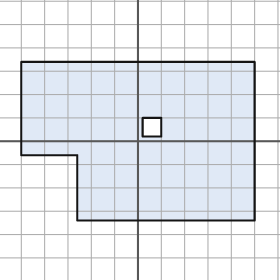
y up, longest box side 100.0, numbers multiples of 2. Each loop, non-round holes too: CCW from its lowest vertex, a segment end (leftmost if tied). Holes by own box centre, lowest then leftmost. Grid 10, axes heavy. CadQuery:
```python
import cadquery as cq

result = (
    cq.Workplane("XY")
    .moveTo(-26.0, -34.0)
    .lineTo(50.0, -34.0)
    .lineTo(50.0, 34.0)
    .lineTo(-50.0, 34.0)
    .lineTo(-50.0, -6.0)
    .lineTo(-26.0, -6.0)
    .close()
    .moveTo(2.0, 2.0)
    .lineTo(10.0, 2.0)
    .lineTo(10.0, 10.0)
    .lineTo(2.0, 10.0)
    .close()
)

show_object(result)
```